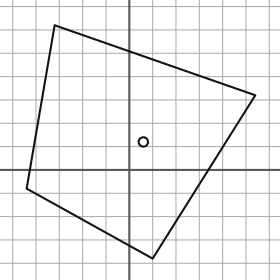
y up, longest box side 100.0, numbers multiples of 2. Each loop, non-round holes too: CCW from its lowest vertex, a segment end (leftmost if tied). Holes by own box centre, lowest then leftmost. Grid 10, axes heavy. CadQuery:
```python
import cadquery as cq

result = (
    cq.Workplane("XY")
    .moveTo(10.0, -38.0)
    .lineTo(54.0, 32.0)
    .lineTo(-32.0, 62.0)
    .lineTo(-44.0, -8.0)
    .close()
    .moveTo(6.0, 12.0)
    .circle(2.0)
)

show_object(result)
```